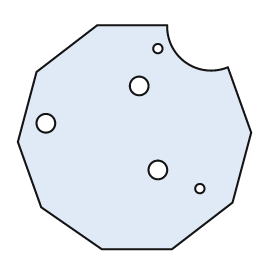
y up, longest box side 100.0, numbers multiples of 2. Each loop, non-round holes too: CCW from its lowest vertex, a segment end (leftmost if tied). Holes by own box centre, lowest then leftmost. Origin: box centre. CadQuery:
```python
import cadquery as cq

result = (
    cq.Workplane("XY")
    .moveTo(-14.0, -48.0)
    .lineTo(16.0, -48.0)
    .lineTo(42.0, -28.0)
    .lineTo(50.0, 2.0)
    .lineTo(40.0, 30.0)
    .threePointArc((22.0, 32.0), (14.0, 48.0))
    .lineTo(-16.0, 48.0)
    .lineTo(-42.0, 28.0)
    .lineTo(-50.0, -2.0)
    .lineTo(-40.0, -30.0)
    .close()
    .moveTo(28.0, -22.0)
    .circle(2.0)
    .moveTo(10.0, -14.0)
    .circle(4.0)
    .moveTo(-38.0, 6.0)
    .circle(4.0)
    .moveTo(2.0, 22.0)
    .circle(4.0)
    .moveTo(10.0, 38.0)
    .circle(2.0)
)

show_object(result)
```